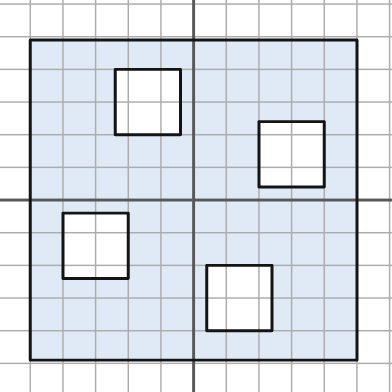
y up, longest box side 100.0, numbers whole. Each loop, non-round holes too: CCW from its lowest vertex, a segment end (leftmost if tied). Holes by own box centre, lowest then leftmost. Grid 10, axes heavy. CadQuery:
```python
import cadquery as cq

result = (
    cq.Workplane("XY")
    .moveTo(-50.0, -49.0)
    .lineTo(50.0, -49.0)
    .lineTo(50.0, 49.0)
    .lineTo(-50.0, 49.0)
    .close()
    .moveTo(4.0, -40.0)
    .lineTo(24.0, -40.0)
    .lineTo(24.0, -20.0)
    .lineTo(4.0, -20.0)
    .close()
    .moveTo(-40.0, -24.0)
    .lineTo(-20.0, -24.0)
    .lineTo(-20.0, -4.0)
    .lineTo(-40.0, -4.0)
    .close()
    .moveTo(20.0, 4.0)
    .lineTo(40.0, 4.0)
    .lineTo(40.0, 24.0)
    .lineTo(20.0, 24.0)
    .close()
    .moveTo(-24.0, 20.0)
    .lineTo(-4.0, 20.0)
    .lineTo(-4.0, 40.0)
    .lineTo(-24.0, 40.0)
    .close()
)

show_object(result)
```